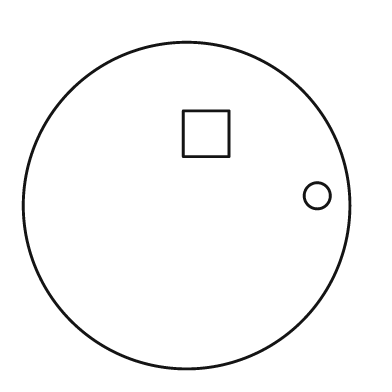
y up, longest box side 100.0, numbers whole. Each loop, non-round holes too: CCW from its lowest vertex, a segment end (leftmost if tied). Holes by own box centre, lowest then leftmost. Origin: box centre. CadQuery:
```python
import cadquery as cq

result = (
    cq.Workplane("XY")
    .moveTo(0.0, 0.0)
    .circle(50.0)
    .moveTo(40.0, 3.0)
    .circle(4.0)
    .moveTo(-1.0, 15.0)
    .lineTo(13.0, 15.0)
    .lineTo(13.0, 29.0)
    .lineTo(-1.0, 29.0)
    .close()
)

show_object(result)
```